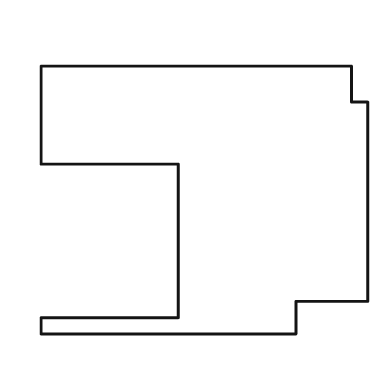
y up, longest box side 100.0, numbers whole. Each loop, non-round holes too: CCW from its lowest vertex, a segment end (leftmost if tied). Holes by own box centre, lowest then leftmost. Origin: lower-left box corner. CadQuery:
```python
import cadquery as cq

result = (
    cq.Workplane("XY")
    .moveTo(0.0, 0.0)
    .lineTo(78.0, 0.0)
    .lineTo(78.0, 10.0)
    .lineTo(100.0, 10.0)
    .lineTo(100.0, 71.0)
    .lineTo(95.0, 71.0)
    .lineTo(95.0, 82.0)
    .lineTo(0.0, 82.0)
    .lineTo(0.0, 52.0)
    .lineTo(42.0, 52.0)
    .lineTo(42.0, 5.0)
    .lineTo(0.0, 5.0)
    .close()
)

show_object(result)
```